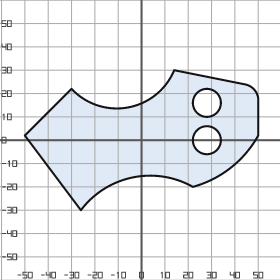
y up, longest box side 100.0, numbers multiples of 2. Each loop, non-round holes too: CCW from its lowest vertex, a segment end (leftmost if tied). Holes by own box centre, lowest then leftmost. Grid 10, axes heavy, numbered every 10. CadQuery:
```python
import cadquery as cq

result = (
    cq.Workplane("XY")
    .moveTo(-26.0, -30.0)
    .threePointArc((-4.0, -16.0), (22.0, -20.0))
    .threePointArc((38.0, -12.0), (50.0, 2.0))
    .lineTo(50.0, 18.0)
    .threePointArc((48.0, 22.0), (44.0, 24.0))
    .lineTo(14.0, 30.0)
    .threePointArc((-6.0, 14.0), (-30.0, 22.0))
    .lineTo(-50.0, 2.0)
    .close()
    .moveTo(28.0, 0.0)
    .circle(6.0)
    .moveTo(28.0, 16.0)
    .circle(6.0)
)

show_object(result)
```